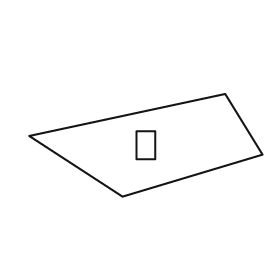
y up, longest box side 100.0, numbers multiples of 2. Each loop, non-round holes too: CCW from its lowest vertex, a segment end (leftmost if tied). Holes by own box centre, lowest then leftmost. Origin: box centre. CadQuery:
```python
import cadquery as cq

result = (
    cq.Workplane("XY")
    .moveTo(-10.0, -22.0)
    .lineTo(50.0, -4.0)
    .lineTo(34.0, 22.0)
    .lineTo(-50.0, 4.0)
    .close()
    .moveTo(-4.0, -6.0)
    .lineTo(4.0, -6.0)
    .lineTo(4.0, 6.0)
    .lineTo(-4.0, 6.0)
    .close()
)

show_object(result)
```